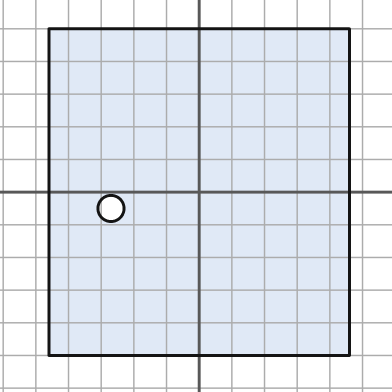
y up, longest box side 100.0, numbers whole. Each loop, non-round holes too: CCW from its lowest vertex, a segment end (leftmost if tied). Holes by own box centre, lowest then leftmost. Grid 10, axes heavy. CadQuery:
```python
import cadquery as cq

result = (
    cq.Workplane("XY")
    .moveTo(-46.0, -50.0)
    .lineTo(46.0, -50.0)
    .lineTo(46.0, 50.0)
    .lineTo(-46.0, 50.0)
    .close()
    .moveTo(-27.0, -5.0)
    .circle(4.0)
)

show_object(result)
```